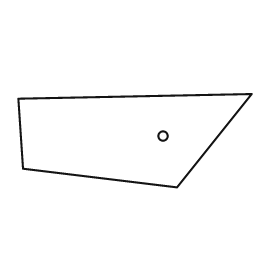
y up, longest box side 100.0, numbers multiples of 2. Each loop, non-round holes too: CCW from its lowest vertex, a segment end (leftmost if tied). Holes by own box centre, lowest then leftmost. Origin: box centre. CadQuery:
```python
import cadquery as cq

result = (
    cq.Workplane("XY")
    .moveTo(18.0, -20.0)
    .lineTo(50.0, 20.0)
    .lineTo(-50.0, 18.0)
    .lineTo(-48.0, -12.0)
    .close()
    .moveTo(12.0, 2.0)
    .circle(2.0)
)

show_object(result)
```